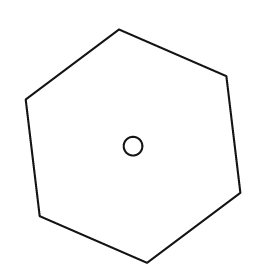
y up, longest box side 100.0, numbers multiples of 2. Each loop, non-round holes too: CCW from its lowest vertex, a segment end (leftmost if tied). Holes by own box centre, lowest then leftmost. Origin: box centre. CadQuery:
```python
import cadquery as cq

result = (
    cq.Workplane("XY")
    .moveTo(6.0, -50.0)
    .lineTo(46.0, -20.0)
    .lineTo(40.0, 30.0)
    .lineTo(-6.0, 50.0)
    .lineTo(-46.0, 20.0)
    .lineTo(-40.0, -30.0)
    .close()
    .moveTo(0.0, 0.0)
    .circle(4.0)
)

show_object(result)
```